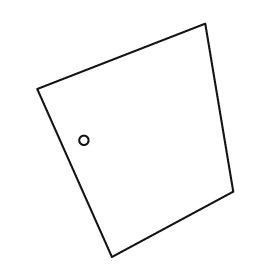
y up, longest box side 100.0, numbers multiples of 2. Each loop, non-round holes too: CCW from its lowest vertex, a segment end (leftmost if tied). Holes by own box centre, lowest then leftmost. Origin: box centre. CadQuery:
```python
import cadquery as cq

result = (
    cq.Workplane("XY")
    .moveTo(-10.0, -50.0)
    .lineTo(42.0, -22.0)
    .lineTo(30.0, 50.0)
    .lineTo(-42.0, 22.0)
    .close()
    .moveTo(-22.0, 0.0)
    .circle(2.0)
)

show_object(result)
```